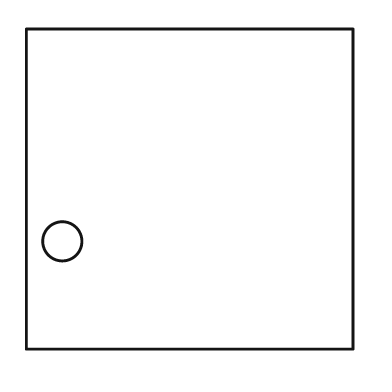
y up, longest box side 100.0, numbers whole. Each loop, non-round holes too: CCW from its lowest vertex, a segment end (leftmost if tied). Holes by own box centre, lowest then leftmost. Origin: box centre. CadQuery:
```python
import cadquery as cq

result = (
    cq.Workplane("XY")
    .moveTo(-50.0, -49.0)
    .lineTo(50.0, -49.0)
    .lineTo(50.0, 49.0)
    .lineTo(-50.0, 49.0)
    .close()
    .moveTo(-39.0, -16.0)
    .circle(6.0)
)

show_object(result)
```